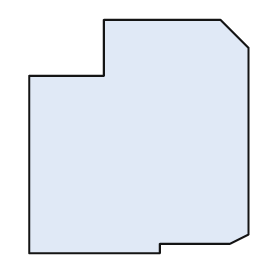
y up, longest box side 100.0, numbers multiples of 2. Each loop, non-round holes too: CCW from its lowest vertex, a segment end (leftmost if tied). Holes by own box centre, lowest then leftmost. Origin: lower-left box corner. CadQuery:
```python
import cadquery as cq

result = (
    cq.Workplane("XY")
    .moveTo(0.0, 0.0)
    .lineTo(56.0, 0.0)
    .lineTo(56.0, 4.0)
    .lineTo(86.0, 4.0)
    .lineTo(94.0, 8.0)
    .lineTo(94.0, 88.0)
    .lineTo(82.0, 100.0)
    .lineTo(32.0, 100.0)
    .lineTo(32.0, 76.0)
    .lineTo(0.0, 76.0)
    .close()
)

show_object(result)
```